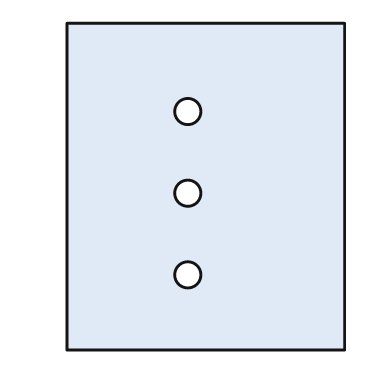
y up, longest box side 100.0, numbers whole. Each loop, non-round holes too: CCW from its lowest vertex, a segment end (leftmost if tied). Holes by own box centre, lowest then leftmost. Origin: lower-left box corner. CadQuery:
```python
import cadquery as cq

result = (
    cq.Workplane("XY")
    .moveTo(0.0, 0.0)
    .lineTo(85.0, 0.0)
    .lineTo(85.0, 100.0)
    .lineTo(0.0, 100.0)
    .close()
    .moveTo(37.0, 23.0)
    .circle(4.0)
    .moveTo(37.0, 48.0)
    .circle(4.0)
    .moveTo(37.0, 73.0)
    .circle(4.0)
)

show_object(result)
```